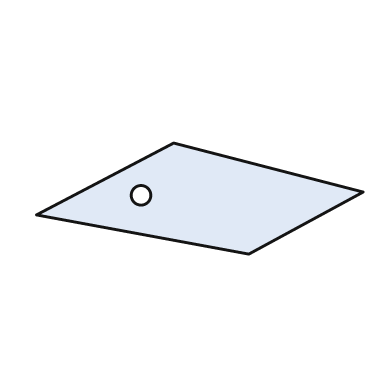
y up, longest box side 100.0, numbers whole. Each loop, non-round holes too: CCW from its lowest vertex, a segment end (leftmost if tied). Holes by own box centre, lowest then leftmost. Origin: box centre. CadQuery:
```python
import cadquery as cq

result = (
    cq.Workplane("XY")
    .moveTo(15.0, -17.0)
    .lineTo(50.0, 2.0)
    .lineTo(-8.0, 17.0)
    .lineTo(-50.0, -5.0)
    .close()
    .moveTo(-18.0, 1.0)
    .circle(3.0)
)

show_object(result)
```